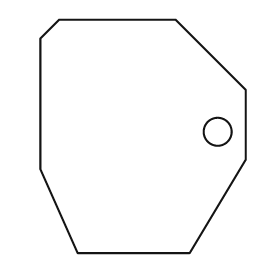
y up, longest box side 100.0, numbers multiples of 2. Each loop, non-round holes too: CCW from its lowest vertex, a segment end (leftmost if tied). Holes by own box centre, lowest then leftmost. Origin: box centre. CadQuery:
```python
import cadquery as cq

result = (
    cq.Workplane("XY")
    .moveTo(-28.0, -50.0)
    .lineTo(20.0, -50.0)
    .lineTo(44.0, -10.0)
    .lineTo(44.0, 20.0)
    .lineTo(14.0, 50.0)
    .lineTo(-36.0, 50.0)
    .lineTo(-44.0, 42.0)
    .lineTo(-44.0, -14.0)
    .close()
    .moveTo(32.0, 2.0)
    .circle(6.0)
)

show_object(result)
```